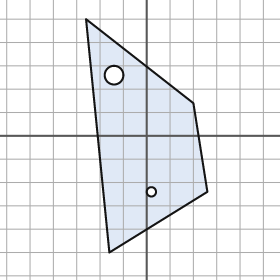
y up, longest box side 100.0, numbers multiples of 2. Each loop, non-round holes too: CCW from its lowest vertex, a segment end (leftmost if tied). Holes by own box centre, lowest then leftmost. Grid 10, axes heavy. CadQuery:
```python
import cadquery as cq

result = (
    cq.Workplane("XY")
    .moveTo(-16.0, -50.0)
    .lineTo(26.0, -24.0)
    .lineTo(20.0, 14.0)
    .lineTo(-26.0, 50.0)
    .close()
    .moveTo(2.0, -24.0)
    .circle(2.0)
    .moveTo(-14.0, 26.0)
    .circle(4.0)
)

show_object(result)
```